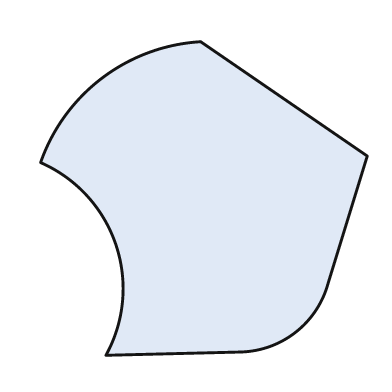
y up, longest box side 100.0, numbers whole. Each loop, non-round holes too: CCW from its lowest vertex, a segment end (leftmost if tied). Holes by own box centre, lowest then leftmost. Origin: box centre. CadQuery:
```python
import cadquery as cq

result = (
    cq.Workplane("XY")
    .moveTo(-30.0, -48.0)
    .lineTo(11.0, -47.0)
    .threePointArc((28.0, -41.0), (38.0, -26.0))
    .lineTo(50.0, 13.0)
    .lineTo(-1.0, 48.0)
    .threePointArc((-31.0, 37.0), (-50.0, 11.0))
    .threePointArc((-27.0, -14.0), (-30.0, -48.0))
    .close()
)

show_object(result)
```